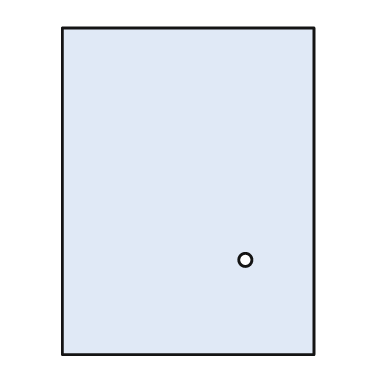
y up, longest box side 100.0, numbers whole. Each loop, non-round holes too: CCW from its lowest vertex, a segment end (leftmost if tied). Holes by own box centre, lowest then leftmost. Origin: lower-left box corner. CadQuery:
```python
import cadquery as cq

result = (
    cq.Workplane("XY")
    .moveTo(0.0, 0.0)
    .lineTo(77.0, 0.0)
    .lineTo(77.0, 100.0)
    .lineTo(0.0, 100.0)
    .close()
    .moveTo(56.0, 29.0)
    .circle(2.0)
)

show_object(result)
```